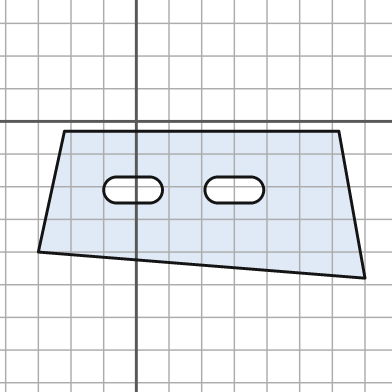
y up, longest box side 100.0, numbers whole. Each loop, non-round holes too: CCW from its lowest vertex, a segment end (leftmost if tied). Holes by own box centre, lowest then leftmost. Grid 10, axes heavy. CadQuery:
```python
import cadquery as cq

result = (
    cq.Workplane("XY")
    .moveTo(70.0, -48.0)
    .lineTo(62.0, -3.0)
    .lineTo(-22.0, -3.0)
    .lineTo(-30.0, -40.0)
    .close()
    .moveTo(-6.0, -25.0)
    .lineTo(4.0, -25.0)
    .threePointArc((8.0, -21.0), (4.0, -17.0))
    .lineTo(-6.0, -17.0)
    .threePointArc((-10.0, -21.0), (-6.0, -25.0))
    .close()
    .moveTo(25.0, -25.0)
    .lineTo(35.0, -25.0)
    .threePointArc((39.0, -21.0), (35.0, -17.0))
    .lineTo(25.0, -17.0)
    .threePointArc((21.0, -21.0), (25.0, -25.0))
    .close()
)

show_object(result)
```